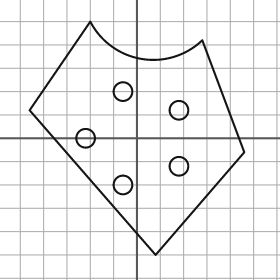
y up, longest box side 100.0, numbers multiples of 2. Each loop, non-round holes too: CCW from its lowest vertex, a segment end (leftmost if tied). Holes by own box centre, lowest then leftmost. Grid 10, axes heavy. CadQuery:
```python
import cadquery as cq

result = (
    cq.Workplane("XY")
    .moveTo(8.0, -50.0)
    .lineTo(46.0, -6.0)
    .lineTo(28.0, 42.0)
    .threePointArc((2.0, 34.0), (-20.0, 50.0))
    .lineTo(-46.0, 12.0)
    .close()
    .moveTo(-6.0, -20.0)
    .circle(4.0)
    .moveTo(18.0, -12.0)
    .circle(4.0)
    .moveTo(-22.0, 0.0)
    .circle(4.0)
    .moveTo(18.0, 12.0)
    .circle(4.0)
    .moveTo(-6.0, 20.0)
    .circle(4.0)
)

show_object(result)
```